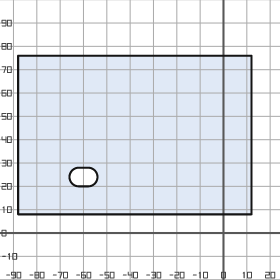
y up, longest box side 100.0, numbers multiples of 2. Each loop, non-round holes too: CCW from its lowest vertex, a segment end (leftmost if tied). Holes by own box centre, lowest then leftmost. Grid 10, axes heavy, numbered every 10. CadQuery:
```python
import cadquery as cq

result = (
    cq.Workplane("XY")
    .moveTo(-88.0, 8.0)
    .lineTo(12.0, 8.0)
    .lineTo(12.0, 76.0)
    .lineTo(-88.0, 76.0)
    .close()
    .moveTo(-62.0, 20.0)
    .lineTo(-58.0, 20.0)
    .threePointArc((-54.0, 24.0), (-58.0, 28.0))
    .lineTo(-62.0, 28.0)
    .threePointArc((-66.0, 24.0), (-62.0, 20.0))
    .close()
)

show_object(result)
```